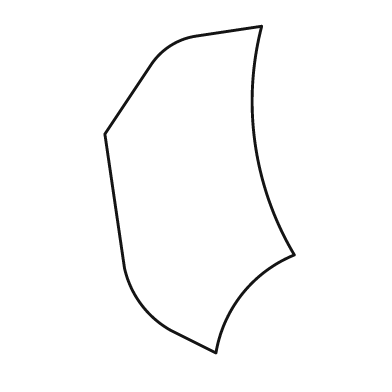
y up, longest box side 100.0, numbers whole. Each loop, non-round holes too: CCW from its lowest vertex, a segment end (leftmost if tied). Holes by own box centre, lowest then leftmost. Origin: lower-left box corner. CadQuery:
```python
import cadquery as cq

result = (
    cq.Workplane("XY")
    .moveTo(34.0, 0.0)
    .threePointArc((42.0, 18.0), (58.0, 30.0))
    .threePointArc((46.0, 64.0), (48.0, 100.0))
    .lineTo(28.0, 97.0)
    .threePointArc((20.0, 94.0), (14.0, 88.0))
    .lineTo(0.0, 67.0)
    .lineTo(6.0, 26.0)
    .threePointArc((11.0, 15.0), (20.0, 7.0))
    .close()
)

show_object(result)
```